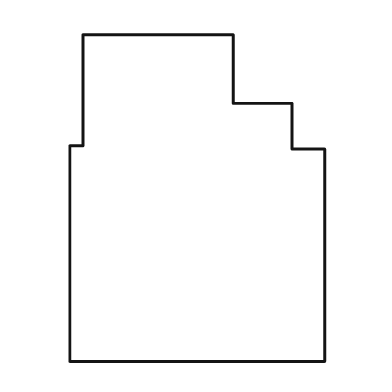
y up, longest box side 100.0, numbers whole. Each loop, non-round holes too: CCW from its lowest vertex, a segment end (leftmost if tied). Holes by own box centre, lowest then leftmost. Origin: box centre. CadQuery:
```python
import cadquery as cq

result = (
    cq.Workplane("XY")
    .moveTo(-39.0, -50.0)
    .lineTo(39.0, -50.0)
    .lineTo(39.0, 15.0)
    .lineTo(29.0, 15.0)
    .lineTo(29.0, 29.0)
    .lineTo(11.0, 29.0)
    .lineTo(11.0, 50.0)
    .lineTo(-35.0, 50.0)
    .lineTo(-35.0, 16.0)
    .lineTo(-39.0, 16.0)
    .close()
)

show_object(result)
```